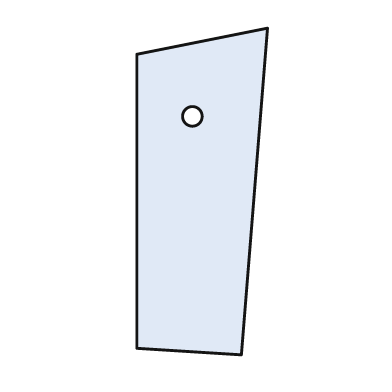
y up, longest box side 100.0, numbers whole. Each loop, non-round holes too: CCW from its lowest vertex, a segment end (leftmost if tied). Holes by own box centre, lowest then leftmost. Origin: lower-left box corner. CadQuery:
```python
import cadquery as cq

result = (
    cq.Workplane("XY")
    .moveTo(32.0, 0.0)
    .lineTo(40.0, 100.0)
    .lineTo(0.0, 92.0)
    .lineTo(0.0, 2.0)
    .close()
    .moveTo(17.0, 73.0)
    .circle(3.0)
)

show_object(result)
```